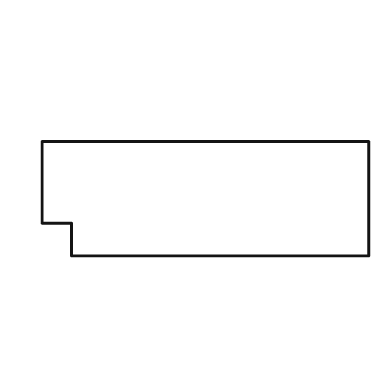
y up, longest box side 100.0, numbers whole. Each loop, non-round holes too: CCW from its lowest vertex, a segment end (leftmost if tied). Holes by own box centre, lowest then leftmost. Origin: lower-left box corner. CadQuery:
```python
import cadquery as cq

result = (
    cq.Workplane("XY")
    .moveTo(9.0, 0.0)
    .lineTo(100.0, 0.0)
    .lineTo(100.0, 35.0)
    .lineTo(0.0, 35.0)
    .lineTo(0.0, 10.0)
    .lineTo(9.0, 10.0)
    .close()
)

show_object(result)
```